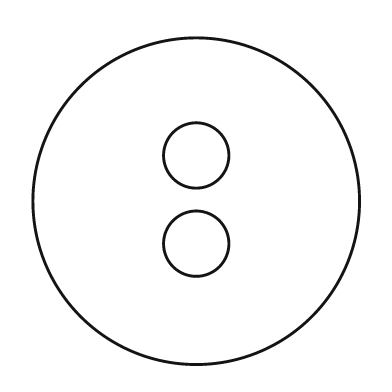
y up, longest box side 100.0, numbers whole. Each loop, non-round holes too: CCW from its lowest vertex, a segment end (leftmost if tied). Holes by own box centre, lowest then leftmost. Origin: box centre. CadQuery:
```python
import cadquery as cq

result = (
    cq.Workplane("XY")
    .moveTo(0.0, 0.0)
    .circle(50.0)
    .moveTo(0.0, -13.0)
    .circle(10.0)
    .moveTo(0.0, 14.0)
    .circle(10.0)
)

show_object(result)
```